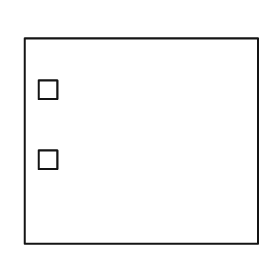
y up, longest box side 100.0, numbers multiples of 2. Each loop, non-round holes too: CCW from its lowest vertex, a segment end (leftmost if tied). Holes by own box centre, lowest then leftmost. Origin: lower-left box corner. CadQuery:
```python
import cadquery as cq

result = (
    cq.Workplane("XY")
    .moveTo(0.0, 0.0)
    .lineTo(100.0, 0.0)
    .lineTo(100.0, 88.0)
    .lineTo(0.0, 88.0)
    .close()
    .moveTo(6.0, 32.0)
    .lineTo(14.0, 32.0)
    .lineTo(14.0, 40.0)
    .lineTo(6.0, 40.0)
    .close()
    .moveTo(6.0, 62.0)
    .lineTo(14.0, 62.0)
    .lineTo(14.0, 70.0)
    .lineTo(6.0, 70.0)
    .close()
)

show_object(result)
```